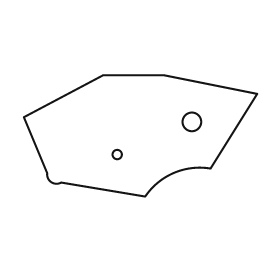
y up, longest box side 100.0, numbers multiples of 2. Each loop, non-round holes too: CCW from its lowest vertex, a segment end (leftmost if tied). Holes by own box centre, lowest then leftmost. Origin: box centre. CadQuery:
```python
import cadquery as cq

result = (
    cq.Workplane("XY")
    .moveTo(2.0, -26.0)
    .threePointArc((14.0, -16.0), (30.0, -14.0))
    .lineTo(50.0, 18.0)
    .lineTo(10.0, 26.0)
    .lineTo(-16.0, 26.0)
    .lineTo(-50.0, 8.0)
    .lineTo(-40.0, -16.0)
    .threePointArc((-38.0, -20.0), (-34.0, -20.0))
    .close()
    .moveTo(-10.0, -8.0)
    .circle(2.0)
    .moveTo(22.0, 6.0)
    .circle(4.0)
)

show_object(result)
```